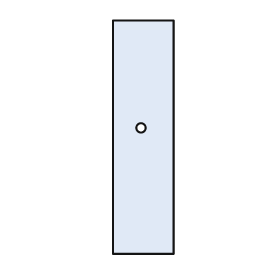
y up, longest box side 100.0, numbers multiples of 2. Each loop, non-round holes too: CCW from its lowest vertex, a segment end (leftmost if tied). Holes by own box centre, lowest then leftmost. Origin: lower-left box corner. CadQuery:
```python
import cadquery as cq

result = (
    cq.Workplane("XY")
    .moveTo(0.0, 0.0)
    .lineTo(26.0, 0.0)
    .lineTo(26.0, 100.0)
    .lineTo(0.0, 100.0)
    .close()
    .moveTo(12.0, 54.0)
    .circle(2.0)
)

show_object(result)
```